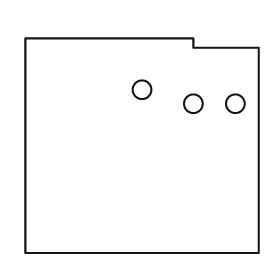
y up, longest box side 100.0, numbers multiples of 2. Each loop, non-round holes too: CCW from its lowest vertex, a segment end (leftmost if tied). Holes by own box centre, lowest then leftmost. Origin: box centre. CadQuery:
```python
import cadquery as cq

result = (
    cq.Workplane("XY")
    .moveTo(-50.0, -46.0)
    .lineTo(50.0, -46.0)
    .lineTo(50.0, 42.0)
    .lineTo(22.0, 42.0)
    .lineTo(22.0, 46.0)
    .lineTo(-50.0, 46.0)
    .close()
    .moveTo(22.0, 18.0)
    .circle(4.0)
    .moveTo(40.0, 18.0)
    .circle(4.0)
    .moveTo(0.0, 24.0)
    .circle(4.0)
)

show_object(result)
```